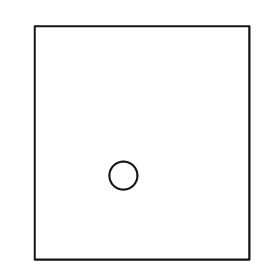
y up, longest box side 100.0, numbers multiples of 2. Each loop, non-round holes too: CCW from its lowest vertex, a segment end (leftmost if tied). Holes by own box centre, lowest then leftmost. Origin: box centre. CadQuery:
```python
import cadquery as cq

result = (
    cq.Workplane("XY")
    .moveTo(-46.0, -50.0)
    .lineTo(46.0, -50.0)
    .lineTo(46.0, 50.0)
    .lineTo(-46.0, 50.0)
    .close()
    .moveTo(-8.0, -14.0)
    .circle(6.0)
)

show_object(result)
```